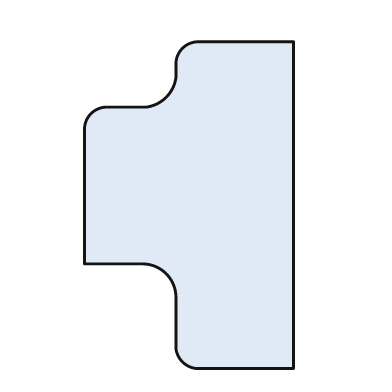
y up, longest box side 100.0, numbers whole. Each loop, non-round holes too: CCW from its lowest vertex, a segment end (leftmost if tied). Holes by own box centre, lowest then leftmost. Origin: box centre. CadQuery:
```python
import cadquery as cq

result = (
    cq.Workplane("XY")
    .moveTo(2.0, -50.0)
    .lineTo(32.0, -50.0)
    .lineTo(32.0, 50.0)
    .lineTo(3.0, 50.0)
    .threePointArc((-2.0, 48.0), (-4.0, 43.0))
    .lineTo(-4.0, 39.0)
    .threePointArc((-7.0, 33.0), (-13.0, 30.0))
    .lineTo(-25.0, 30.0)
    .threePointArc((-30.0, 28.0), (-32.0, 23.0))
    .lineTo(-32.0, -18.0)
    .lineTo(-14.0, -18.0)
    .threePointArc((-7.0, -21.0), (-4.0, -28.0))
    .lineTo(-4.0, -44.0)
    .threePointArc((-2.0, -48.0), (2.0, -50.0))
    .close()
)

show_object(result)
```